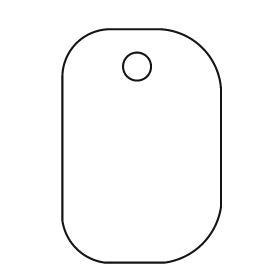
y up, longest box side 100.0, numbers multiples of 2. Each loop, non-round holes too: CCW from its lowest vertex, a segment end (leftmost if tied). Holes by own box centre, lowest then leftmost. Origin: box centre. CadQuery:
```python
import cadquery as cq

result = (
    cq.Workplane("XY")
    .moveTo(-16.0, -50.0)
    .lineTo(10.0, -50.0)
    .threePointArc((26.0, -42.0), (34.0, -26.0))
    .lineTo(34.0, 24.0)
    .threePointArc((26.0, 42.0), (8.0, 50.0))
    .lineTo(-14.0, 50.0)
    .threePointArc((-28.0, 44.0), (-34.0, 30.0))
    .lineTo(-34.0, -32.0)
    .threePointArc((-28.0, -44.0), (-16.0, -50.0))
    .close()
    .moveTo(-2.0, 34.0)
    .circle(6.0)
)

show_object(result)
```